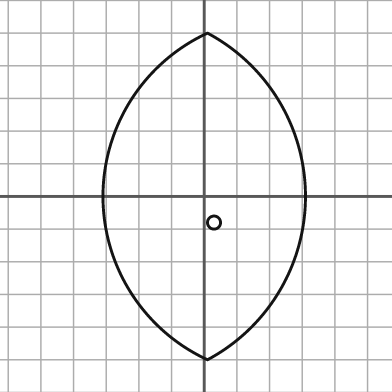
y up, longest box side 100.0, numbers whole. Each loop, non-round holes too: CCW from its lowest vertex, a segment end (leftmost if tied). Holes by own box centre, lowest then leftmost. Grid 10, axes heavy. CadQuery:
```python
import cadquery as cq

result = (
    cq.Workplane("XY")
    .moveTo(1.0, -50.0)
    .threePointArc((31.0, 0.0), (1.0, 50.0))
    .threePointArc((-31.0, 0.0), (1.0, -50.0))
    .close()
    .moveTo(3.0, -8.0)
    .circle(2.0)
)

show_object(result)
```